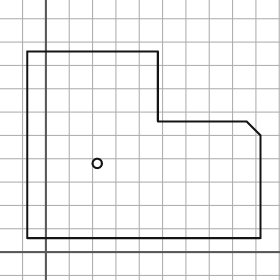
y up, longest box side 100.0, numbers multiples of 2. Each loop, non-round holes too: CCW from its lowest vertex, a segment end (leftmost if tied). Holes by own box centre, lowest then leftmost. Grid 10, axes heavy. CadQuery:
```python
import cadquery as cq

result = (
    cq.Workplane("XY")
    .moveTo(-8.0, 6.0)
    .lineTo(92.0, 6.0)
    .lineTo(92.0, 50.0)
    .lineTo(86.0, 56.0)
    .lineTo(48.0, 56.0)
    .lineTo(48.0, 86.0)
    .lineTo(-8.0, 86.0)
    .close()
    .moveTo(22.0, 38.0)
    .circle(2.0)
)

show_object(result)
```